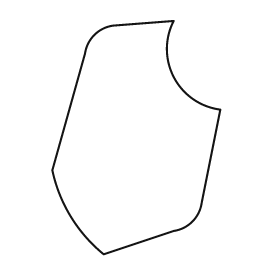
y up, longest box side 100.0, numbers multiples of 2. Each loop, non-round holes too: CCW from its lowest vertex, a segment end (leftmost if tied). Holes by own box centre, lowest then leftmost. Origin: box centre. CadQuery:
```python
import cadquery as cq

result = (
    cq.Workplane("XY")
    .moveTo(-14.0, -50.0)
    .lineTo(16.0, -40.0)
    .threePointArc((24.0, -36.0), (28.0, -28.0))
    .lineTo(36.0, 12.0)
    .threePointArc((16.0, 26.0), (16.0, 50.0))
    .lineTo(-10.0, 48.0)
    .threePointArc((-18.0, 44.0), (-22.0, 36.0))
    .lineTo(-36.0, -14.0)
    .threePointArc((-28.0, -34.0), (-14.0, -50.0))
    .close()
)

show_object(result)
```